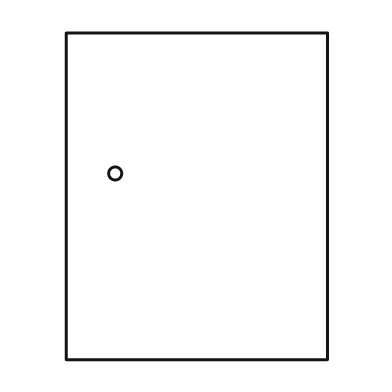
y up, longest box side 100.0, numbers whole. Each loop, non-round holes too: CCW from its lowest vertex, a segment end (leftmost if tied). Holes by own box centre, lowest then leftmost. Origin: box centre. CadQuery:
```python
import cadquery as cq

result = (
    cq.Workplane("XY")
    .moveTo(-40.0, -50.0)
    .lineTo(40.0, -50.0)
    .lineTo(40.0, 50.0)
    .lineTo(-40.0, 50.0)
    .close()
    .moveTo(-25.0, 7.0)
    .circle(2.0)
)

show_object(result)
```